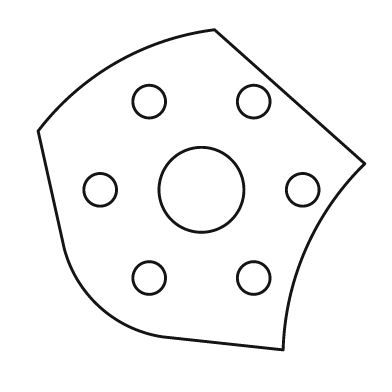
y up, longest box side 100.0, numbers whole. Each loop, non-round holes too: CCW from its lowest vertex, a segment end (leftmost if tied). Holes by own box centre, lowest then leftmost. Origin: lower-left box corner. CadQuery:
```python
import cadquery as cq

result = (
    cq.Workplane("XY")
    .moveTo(75.0, 0.0)
    .threePointArc((82.0, 31.0), (100.0, 57.0))
    .lineTo(54.0, 98.0)
    .threePointArc((24.0, 88.0), (0.0, 67.0))
    .lineTo(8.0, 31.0)
    .threePointArc((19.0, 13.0), (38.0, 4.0))
    .close()
    .moveTo(34.0, 22.0)
    .circle(5.0)
    .moveTo(66.0, 22.0)
    .circle(5.0)
    .moveTo(19.0, 49.0)
    .circle(5.0)
    .moveTo(50.0, 49.0)
    .circle(13.0)
    .moveTo(81.0, 49.0)
    .circle(5.0)
    .moveTo(34.0, 76.0)
    .circle(5.0)
    .moveTo(66.0, 76.0)
    .circle(5.0)
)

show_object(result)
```